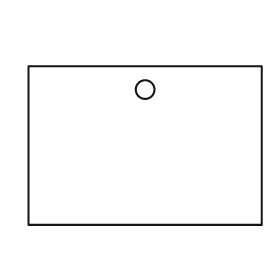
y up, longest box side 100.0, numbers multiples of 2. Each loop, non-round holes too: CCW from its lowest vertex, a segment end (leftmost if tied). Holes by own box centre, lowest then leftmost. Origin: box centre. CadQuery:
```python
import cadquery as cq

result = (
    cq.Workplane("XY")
    .moveTo(-50.0, -34.0)
    .lineTo(50.0, -34.0)
    .lineTo(50.0, 34.0)
    .lineTo(-50.0, 34.0)
    .close()
    .moveTo(0.0, 24.0)
    .circle(4.0)
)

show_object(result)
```